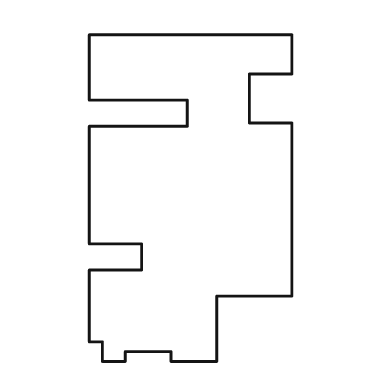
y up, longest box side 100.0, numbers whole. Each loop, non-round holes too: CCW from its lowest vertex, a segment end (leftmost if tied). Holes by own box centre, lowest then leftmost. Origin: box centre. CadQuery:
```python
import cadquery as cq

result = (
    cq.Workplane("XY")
    .moveTo(-27.0, -50.0)
    .lineTo(-20.0, -50.0)
    .lineTo(-20.0, -47.0)
    .lineTo(-6.0, -47.0)
    .lineTo(-6.0, -50.0)
    .lineTo(8.0, -50.0)
    .lineTo(8.0, -30.0)
    .lineTo(31.0, -30.0)
    .lineTo(31.0, 23.0)
    .lineTo(18.0, 23.0)
    .lineTo(18.0, 38.0)
    .lineTo(31.0, 38.0)
    .lineTo(31.0, 50.0)
    .lineTo(-31.0, 50.0)
    .lineTo(-31.0, 30.0)
    .lineTo(-1.0, 30.0)
    .lineTo(-1.0, 22.0)
    .lineTo(-31.0, 22.0)
    .lineTo(-31.0, -14.0)
    .lineTo(-15.0, -14.0)
    .lineTo(-15.0, -22.0)
    .lineTo(-31.0, -22.0)
    .lineTo(-31.0, -44.0)
    .lineTo(-27.0, -44.0)
    .close()
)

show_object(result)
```